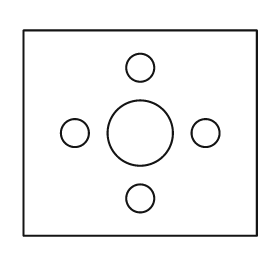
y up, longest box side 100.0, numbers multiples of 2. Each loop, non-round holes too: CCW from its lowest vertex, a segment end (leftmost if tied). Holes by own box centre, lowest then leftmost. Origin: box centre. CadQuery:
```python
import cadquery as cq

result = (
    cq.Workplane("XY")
    .moveTo(-50.0, -44.0)
    .lineTo(50.0, -44.0)
    .lineTo(50.0, 44.0)
    .lineTo(-50.0, 44.0)
    .close()
    .moveTo(0.0, -28.0)
    .circle(6.0)
    .moveTo(-28.0, 0.0)
    .circle(6.0)
    .moveTo(0.0, 0.0)
    .circle(14.0)
    .moveTo(28.0, 0.0)
    .circle(6.0)
    .moveTo(0.0, 28.0)
    .circle(6.0)
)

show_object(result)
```